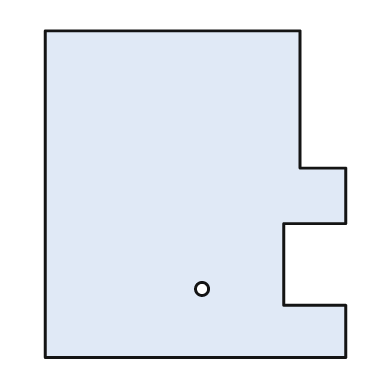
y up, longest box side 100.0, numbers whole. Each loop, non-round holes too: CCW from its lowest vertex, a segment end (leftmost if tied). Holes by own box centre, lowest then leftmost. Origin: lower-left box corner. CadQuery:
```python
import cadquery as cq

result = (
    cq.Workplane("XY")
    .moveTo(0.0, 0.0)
    .lineTo(92.0, 0.0)
    .lineTo(92.0, 16.0)
    .lineTo(73.0, 16.0)
    .lineTo(73.0, 41.0)
    .lineTo(92.0, 41.0)
    .lineTo(92.0, 58.0)
    .lineTo(78.0, 58.0)
    .lineTo(78.0, 100.0)
    .lineTo(0.0, 100.0)
    .close()
    .moveTo(48.0, 21.0)
    .circle(2.0)
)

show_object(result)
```